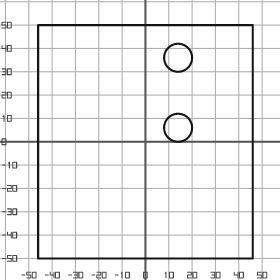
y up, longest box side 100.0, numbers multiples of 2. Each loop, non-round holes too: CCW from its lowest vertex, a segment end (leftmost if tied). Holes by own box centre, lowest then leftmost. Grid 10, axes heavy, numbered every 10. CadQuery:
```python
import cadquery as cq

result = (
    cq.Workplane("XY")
    .moveTo(-46.0, -50.0)
    .lineTo(46.0, -50.0)
    .lineTo(46.0, 50.0)
    .lineTo(-46.0, 50.0)
    .close()
    .moveTo(14.0, 6.0)
    .circle(6.0)
    .moveTo(14.0, 36.0)
    .circle(6.0)
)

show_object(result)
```